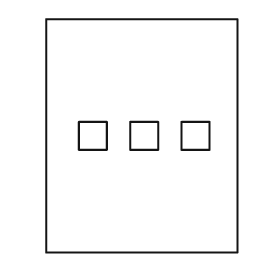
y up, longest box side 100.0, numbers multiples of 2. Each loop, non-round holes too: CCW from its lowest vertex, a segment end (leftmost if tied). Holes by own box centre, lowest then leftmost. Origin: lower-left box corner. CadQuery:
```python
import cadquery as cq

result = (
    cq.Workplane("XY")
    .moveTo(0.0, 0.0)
    .lineTo(82.0, 0.0)
    .lineTo(82.0, 100.0)
    .lineTo(0.0, 100.0)
    .close()
    .moveTo(14.0, 44.0)
    .lineTo(26.0, 44.0)
    .lineTo(26.0, 56.0)
    .lineTo(14.0, 56.0)
    .close()
    .moveTo(36.0, 44.0)
    .lineTo(48.0, 44.0)
    .lineTo(48.0, 56.0)
    .lineTo(36.0, 56.0)
    .close()
    .moveTo(58.0, 44.0)
    .lineTo(70.0, 44.0)
    .lineTo(70.0, 56.0)
    .lineTo(58.0, 56.0)
    .close()
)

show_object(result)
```